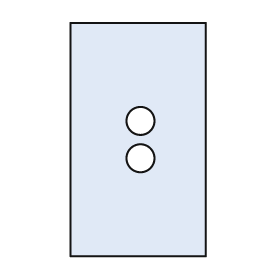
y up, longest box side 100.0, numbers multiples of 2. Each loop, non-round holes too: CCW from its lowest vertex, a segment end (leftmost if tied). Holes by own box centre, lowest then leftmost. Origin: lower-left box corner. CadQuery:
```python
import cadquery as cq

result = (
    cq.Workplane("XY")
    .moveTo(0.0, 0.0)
    .lineTo(58.0, 0.0)
    .lineTo(58.0, 100.0)
    .lineTo(0.0, 100.0)
    .close()
    .moveTo(30.0, 42.0)
    .circle(6.0)
    .moveTo(30.0, 58.0)
    .circle(6.0)
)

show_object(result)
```